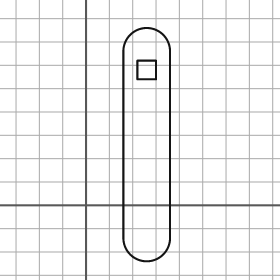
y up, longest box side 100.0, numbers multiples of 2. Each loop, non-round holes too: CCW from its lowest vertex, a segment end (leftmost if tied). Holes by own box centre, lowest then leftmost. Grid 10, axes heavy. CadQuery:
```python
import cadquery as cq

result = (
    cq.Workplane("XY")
    .moveTo(16.0, -14.0)
    .threePointArc((26.0, -24.0), (36.0, -14.0))
    .lineTo(36.0, 66.0)
    .threePointArc((26.0, 76.0), (16.0, 66.0))
    .close()
    .moveTo(22.0, 54.0)
    .lineTo(30.0, 54.0)
    .lineTo(30.0, 62.0)
    .lineTo(22.0, 62.0)
    .close()
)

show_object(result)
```